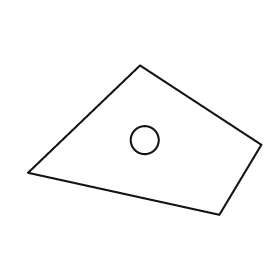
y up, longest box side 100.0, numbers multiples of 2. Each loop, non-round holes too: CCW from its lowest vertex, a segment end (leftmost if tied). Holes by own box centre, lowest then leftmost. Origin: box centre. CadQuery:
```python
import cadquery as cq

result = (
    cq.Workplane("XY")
    .moveTo(32.0, -32.0)
    .lineTo(50.0, -2.0)
    .lineTo(-2.0, 32.0)
    .lineTo(-50.0, -14.0)
    .close()
    .moveTo(0.0, 0.0)
    .circle(6.0)
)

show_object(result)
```